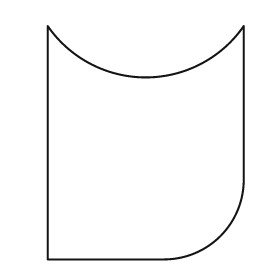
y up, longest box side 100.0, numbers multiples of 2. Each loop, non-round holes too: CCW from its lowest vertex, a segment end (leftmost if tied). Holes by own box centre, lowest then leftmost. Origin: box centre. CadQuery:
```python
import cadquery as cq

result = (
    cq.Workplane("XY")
    .moveTo(-42.0, -50.0)
    .lineTo(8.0, -50.0)
    .threePointArc((32.0, -40.0), (42.0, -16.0))
    .lineTo(42.0, 50.0)
    .threePointArc((0.0, 28.0), (-42.0, 50.0))
    .close()
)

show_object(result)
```